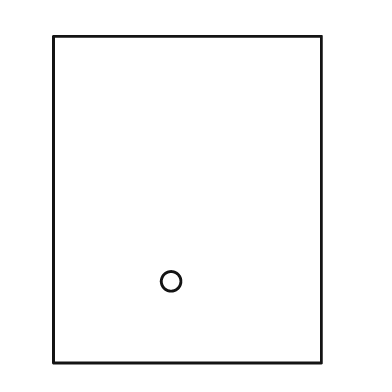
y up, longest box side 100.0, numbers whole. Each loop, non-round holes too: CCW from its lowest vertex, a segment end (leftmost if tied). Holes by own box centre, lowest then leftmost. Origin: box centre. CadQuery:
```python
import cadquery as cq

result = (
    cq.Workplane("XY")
    .moveTo(-41.0, -50.0)
    .lineTo(41.0, -50.0)
    .lineTo(41.0, 50.0)
    .lineTo(-41.0, 50.0)
    .close()
    .moveTo(-5.0, -25.0)
    .circle(3.0)
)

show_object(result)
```